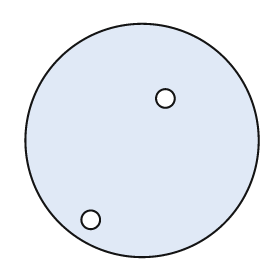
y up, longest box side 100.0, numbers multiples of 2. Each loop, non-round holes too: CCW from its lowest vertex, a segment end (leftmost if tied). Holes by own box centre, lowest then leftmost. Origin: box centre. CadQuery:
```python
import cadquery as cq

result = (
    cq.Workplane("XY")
    .moveTo(0.0, 0.0)
    .circle(50.0)
    .moveTo(-22.0, -34.0)
    .circle(4.0)
    .moveTo(10.0, 18.0)
    .circle(4.0)
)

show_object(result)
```